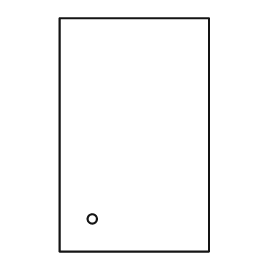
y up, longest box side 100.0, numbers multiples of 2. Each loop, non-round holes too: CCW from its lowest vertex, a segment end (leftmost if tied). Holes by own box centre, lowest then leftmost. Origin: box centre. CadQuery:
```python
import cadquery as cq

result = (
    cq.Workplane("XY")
    .moveTo(-32.0, -50.0)
    .lineTo(32.0, -50.0)
    .lineTo(32.0, 50.0)
    .lineTo(-32.0, 50.0)
    .close()
    .moveTo(-18.0, -36.0)
    .circle(2.0)
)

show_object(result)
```